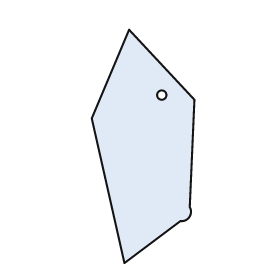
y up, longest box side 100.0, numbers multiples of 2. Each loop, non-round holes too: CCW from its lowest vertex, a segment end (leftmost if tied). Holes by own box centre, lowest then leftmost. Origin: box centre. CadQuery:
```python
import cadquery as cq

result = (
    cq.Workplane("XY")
    .moveTo(-8.0, -50.0)
    .lineTo(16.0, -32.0)
    .threePointArc((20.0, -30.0), (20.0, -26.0))
    .lineTo(22.0, 20.0)
    .lineTo(-6.0, 50.0)
    .lineTo(-22.0, 12.0)
    .close()
    .moveTo(8.0, 22.0)
    .circle(2.0)
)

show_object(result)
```